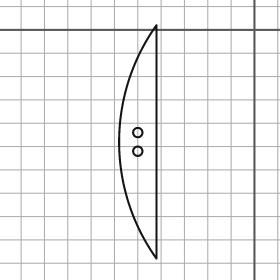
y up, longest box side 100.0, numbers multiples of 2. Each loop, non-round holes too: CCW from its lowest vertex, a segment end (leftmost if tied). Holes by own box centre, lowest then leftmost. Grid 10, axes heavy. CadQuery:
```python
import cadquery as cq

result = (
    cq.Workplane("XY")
    .moveTo(-42.0, -98.0)
    .lineTo(-42.0, 2.0)
    .threePointArc((-58.0, -48.0), (-42.0, -98.0))
    .close()
    .moveTo(-50.0, -52.0)
    .circle(2.0)
    .moveTo(-50.0, -44.0)
    .circle(2.0)
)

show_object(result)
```